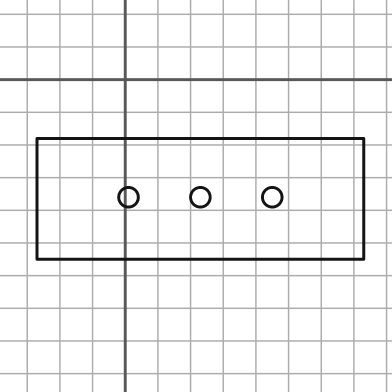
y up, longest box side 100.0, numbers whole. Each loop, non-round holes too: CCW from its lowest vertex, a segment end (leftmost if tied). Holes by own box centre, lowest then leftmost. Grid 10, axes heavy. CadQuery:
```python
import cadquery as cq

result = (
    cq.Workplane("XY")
    .moveTo(-27.0, -55.0)
    .lineTo(73.0, -55.0)
    .lineTo(73.0, -18.0)
    .lineTo(-27.0, -18.0)
    .close()
    .moveTo(1.0, -36.0)
    .circle(3.0)
    .moveTo(23.0, -36.0)
    .circle(3.0)
    .moveTo(45.0, -36.0)
    .circle(3.0)
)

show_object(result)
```